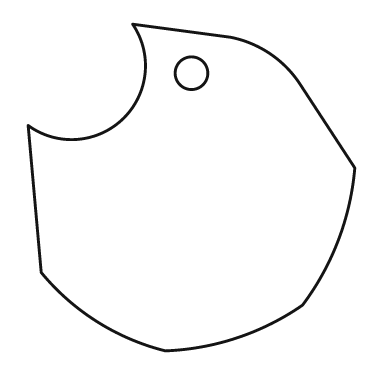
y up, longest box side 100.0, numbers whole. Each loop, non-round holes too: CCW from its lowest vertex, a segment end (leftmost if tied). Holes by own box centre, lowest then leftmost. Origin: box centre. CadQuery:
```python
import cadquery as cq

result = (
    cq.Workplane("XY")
    .moveTo(-8.0, -50.0)
    .threePointArc((14.0, -46.0), (34.0, -36.0))
    .threePointArc((45.0, -16.0), (50.0, 6.0))
    .lineTo(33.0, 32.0)
    .threePointArc((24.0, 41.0), (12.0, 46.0))
    .lineTo(-18.0, 50.0)
    .threePointArc((-21.0, 21.0), (-50.0, 19.0))
    .lineTo(-46.0, -26.0)
    .threePointArc((-29.0, -41.0), (-8.0, -50.0))
    .close()
    .moveTo(0.0, 35.0)
    .circle(5.0)
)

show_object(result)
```